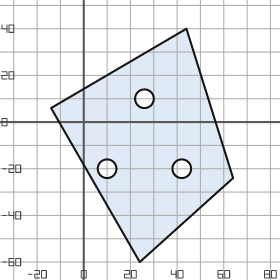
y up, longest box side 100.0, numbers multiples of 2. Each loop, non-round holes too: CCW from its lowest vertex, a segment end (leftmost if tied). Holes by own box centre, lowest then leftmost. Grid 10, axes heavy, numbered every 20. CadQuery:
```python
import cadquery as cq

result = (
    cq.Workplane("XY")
    .moveTo(24.0, -60.0)
    .lineTo(64.0, -24.0)
    .lineTo(44.0, 40.0)
    .lineTo(-14.0, 6.0)
    .close()
    .moveTo(10.0, -20.0)
    .circle(4.0)
    .moveTo(42.0, -20.0)
    .circle(4.0)
    .moveTo(26.0, 10.0)
    .circle(4.0)
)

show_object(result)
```